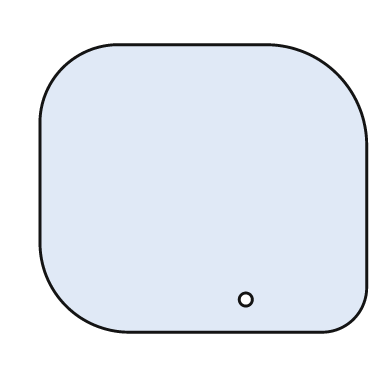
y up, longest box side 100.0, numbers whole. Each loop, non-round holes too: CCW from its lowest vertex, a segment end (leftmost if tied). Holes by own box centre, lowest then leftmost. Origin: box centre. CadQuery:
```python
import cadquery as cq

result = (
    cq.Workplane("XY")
    .moveTo(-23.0, -44.0)
    .lineTo(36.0, -44.0)
    .threePointArc((46.0, -40.0), (50.0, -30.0))
    .lineTo(50.0, 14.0)
    .threePointArc((41.0, 35.0), (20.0, 44.0))
    .lineTo(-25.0, 44.0)
    .threePointArc((-43.0, 37.0), (-50.0, 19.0))
    .lineTo(-50.0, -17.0)
    .threePointArc((-42.0, -36.0), (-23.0, -44.0))
    .close()
    .moveTo(13.0, -34.0)
    .circle(2.0)
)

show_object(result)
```